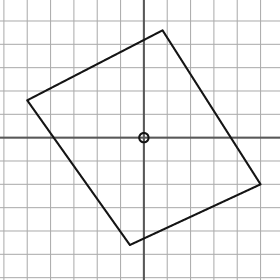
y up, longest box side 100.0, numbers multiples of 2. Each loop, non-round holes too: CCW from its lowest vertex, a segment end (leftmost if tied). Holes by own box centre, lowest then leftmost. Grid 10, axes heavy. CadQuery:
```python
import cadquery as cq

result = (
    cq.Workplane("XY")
    .moveTo(-6.0, -46.0)
    .lineTo(50.0, -20.0)
    .lineTo(8.0, 46.0)
    .lineTo(-50.0, 16.0)
    .close()
    .moveTo(0.0, 0.0)
    .circle(2.0)
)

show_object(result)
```